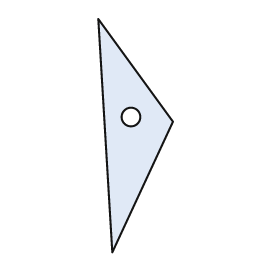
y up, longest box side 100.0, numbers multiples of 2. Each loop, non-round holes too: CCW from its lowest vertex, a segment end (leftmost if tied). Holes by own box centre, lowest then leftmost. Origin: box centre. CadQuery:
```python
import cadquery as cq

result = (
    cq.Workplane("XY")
    .moveTo(-10.0, -50.0)
    .lineTo(16.0, 6.0)
    .lineTo(-16.0, 50.0)
    .close()
    .moveTo(-2.0, 8.0)
    .circle(4.0)
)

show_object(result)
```